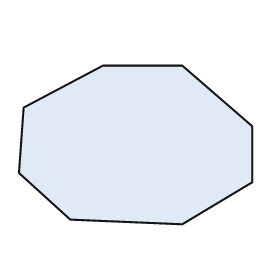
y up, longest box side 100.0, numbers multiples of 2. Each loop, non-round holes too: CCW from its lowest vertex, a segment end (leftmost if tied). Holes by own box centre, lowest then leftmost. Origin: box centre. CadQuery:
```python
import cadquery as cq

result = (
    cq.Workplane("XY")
    .moveTo(20.0, -34.0)
    .lineTo(50.0, -16.0)
    .lineTo(50.0, 8.0)
    .lineTo(20.0, 34.0)
    .lineTo(-14.0, 34.0)
    .lineTo(-48.0, 16.0)
    .lineTo(-50.0, -12.0)
    .lineTo(-28.0, -32.0)
    .close()
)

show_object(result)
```